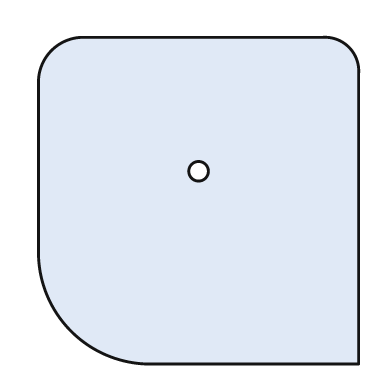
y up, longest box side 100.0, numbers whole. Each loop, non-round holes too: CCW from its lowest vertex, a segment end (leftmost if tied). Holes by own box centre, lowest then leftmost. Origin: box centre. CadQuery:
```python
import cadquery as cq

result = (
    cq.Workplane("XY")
    .moveTo(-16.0, -50.0)
    .lineTo(49.0, -50.0)
    .lineTo(49.0, 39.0)
    .threePointArc((46.0, 47.0), (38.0, 50.0))
    .lineTo(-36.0, 50.0)
    .threePointArc((-45.0, 46.0), (-49.0, 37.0))
    .lineTo(-49.0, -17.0)
    .threePointArc((-39.0, -40.0), (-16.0, -50.0))
    .close()
    .moveTo(0.0, 9.0)
    .circle(3.0)
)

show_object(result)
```